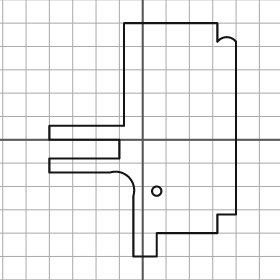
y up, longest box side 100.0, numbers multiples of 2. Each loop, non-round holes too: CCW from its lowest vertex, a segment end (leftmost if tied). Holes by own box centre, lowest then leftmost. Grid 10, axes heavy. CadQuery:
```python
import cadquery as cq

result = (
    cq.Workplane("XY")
    .moveTo(-4.0, -50.0)
    .lineTo(6.0, -50.0)
    .lineTo(6.0, -40.0)
    .lineTo(32.0, -40.0)
    .lineTo(32.0, -32.0)
    .lineTo(40.0, -32.0)
    .lineTo(40.0, 42.0)
    .threePointArc((36.0, 44.0), (32.0, 42.0))
    .lineTo(32.0, 50.0)
    .lineTo(-8.0, 50.0)
    .lineTo(-8.0, 6.0)
    .lineTo(-40.0, 6.0)
    .lineTo(-40.0, 0.0)
    .lineTo(-10.0, 0.0)
    .lineTo(-10.0, -8.0)
    .lineTo(-40.0, -8.0)
    .lineTo(-40.0, -14.0)
    .lineTo(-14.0, -14.0)
    .threePointArc((-6.0, -16.0), (-4.0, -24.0))
    .close()
    .moveTo(6.0, -22.0)
    .circle(2.0)
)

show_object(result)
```